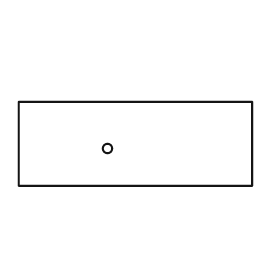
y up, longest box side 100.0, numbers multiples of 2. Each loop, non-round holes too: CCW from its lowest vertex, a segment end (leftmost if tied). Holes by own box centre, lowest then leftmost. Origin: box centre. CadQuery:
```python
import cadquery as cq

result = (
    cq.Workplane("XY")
    .moveTo(-50.0, -18.0)
    .lineTo(50.0, -18.0)
    .lineTo(50.0, 18.0)
    .lineTo(-50.0, 18.0)
    .close()
    .moveTo(-12.0, -2.0)
    .circle(2.0)
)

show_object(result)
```